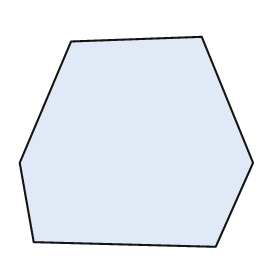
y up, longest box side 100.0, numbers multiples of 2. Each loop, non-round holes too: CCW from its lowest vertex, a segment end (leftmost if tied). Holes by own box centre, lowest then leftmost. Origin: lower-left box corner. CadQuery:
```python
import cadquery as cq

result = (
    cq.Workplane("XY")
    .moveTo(84.0, 0.0)
    .lineTo(100.0, 36.0)
    .lineTo(78.0, 90.0)
    .lineTo(22.0, 88.0)
    .lineTo(0.0, 36.0)
    .lineTo(6.0, 2.0)
    .close()
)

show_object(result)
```